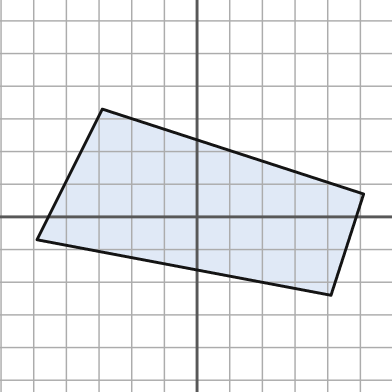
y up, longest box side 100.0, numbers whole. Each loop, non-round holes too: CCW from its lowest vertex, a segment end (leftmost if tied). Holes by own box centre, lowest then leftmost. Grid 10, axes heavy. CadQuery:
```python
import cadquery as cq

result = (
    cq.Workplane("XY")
    .moveTo(41.0, -24.0)
    .lineTo(51.0, 7.0)
    .lineTo(-29.0, 33.0)
    .lineTo(-49.0, -7.0)
    .close()
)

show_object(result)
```